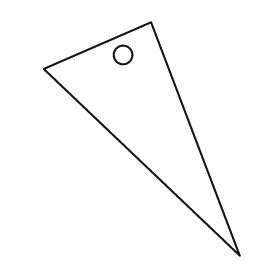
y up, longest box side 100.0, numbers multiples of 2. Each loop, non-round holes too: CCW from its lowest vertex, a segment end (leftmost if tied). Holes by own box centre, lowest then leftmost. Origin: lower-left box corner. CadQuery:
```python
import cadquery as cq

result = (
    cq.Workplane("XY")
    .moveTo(84.0, 0.0)
    .lineTo(46.0, 100.0)
    .lineTo(0.0, 80.0)
    .close()
    .moveTo(34.0, 86.0)
    .circle(4.0)
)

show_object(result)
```